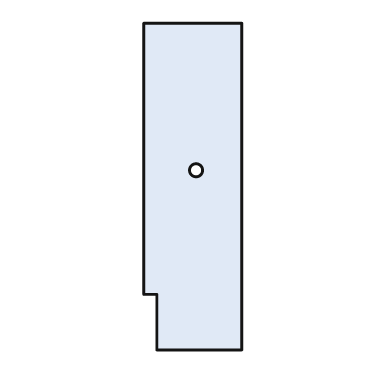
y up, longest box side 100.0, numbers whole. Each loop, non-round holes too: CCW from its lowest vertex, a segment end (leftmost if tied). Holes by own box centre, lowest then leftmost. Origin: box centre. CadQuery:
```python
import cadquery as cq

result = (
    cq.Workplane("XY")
    .moveTo(-11.0, -50.0)
    .lineTo(15.0, -50.0)
    .lineTo(15.0, 50.0)
    .lineTo(-15.0, 50.0)
    .lineTo(-15.0, -33.0)
    .lineTo(-11.0, -33.0)
    .close()
    .moveTo(1.0, 5.0)
    .circle(2.0)
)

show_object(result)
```